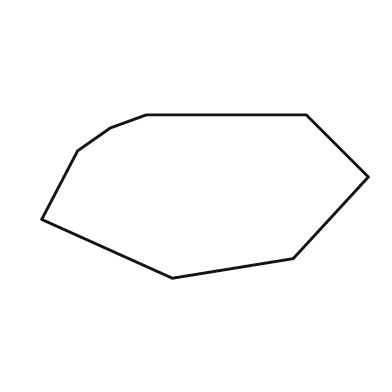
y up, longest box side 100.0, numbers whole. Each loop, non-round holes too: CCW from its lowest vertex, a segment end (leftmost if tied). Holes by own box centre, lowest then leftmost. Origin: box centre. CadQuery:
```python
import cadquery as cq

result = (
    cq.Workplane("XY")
    .moveTo(-10.0, -25.0)
    .lineTo(27.0, -19.0)
    .lineTo(50.0, 6.0)
    .lineTo(31.0, 25.0)
    .lineTo(-18.0, 25.0)
    .lineTo(-29.0, 21.0)
    .lineTo(-39.0, 14.0)
    .lineTo(-50.0, -7.0)
    .close()
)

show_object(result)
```